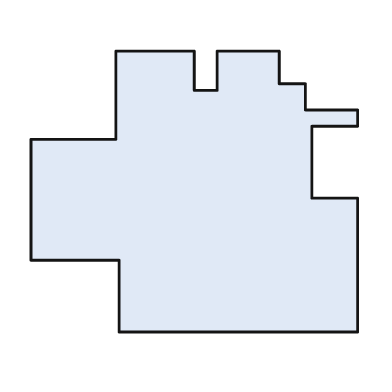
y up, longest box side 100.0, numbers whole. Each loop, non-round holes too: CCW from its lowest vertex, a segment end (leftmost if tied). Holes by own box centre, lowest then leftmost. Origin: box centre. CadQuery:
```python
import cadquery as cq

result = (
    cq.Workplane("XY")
    .moveTo(-23.0, -43.0)
    .lineTo(50.0, -43.0)
    .lineTo(50.0, -2.0)
    .lineTo(36.0, -2.0)
    .lineTo(36.0, 20.0)
    .lineTo(50.0, 20.0)
    .lineTo(50.0, 25.0)
    .lineTo(34.0, 25.0)
    .lineTo(34.0, 33.0)
    .lineTo(26.0, 33.0)
    .lineTo(26.0, 43.0)
    .lineTo(7.0, 43.0)
    .lineTo(7.0, 31.0)
    .lineTo(0.0, 31.0)
    .lineTo(0.0, 43.0)
    .lineTo(-24.0, 43.0)
    .lineTo(-24.0, 16.0)
    .lineTo(-50.0, 16.0)
    .lineTo(-50.0, -21.0)
    .lineTo(-23.0, -21.0)
    .close()
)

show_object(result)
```